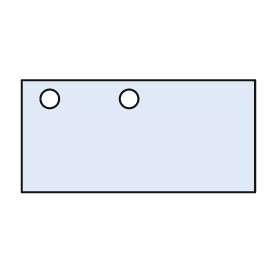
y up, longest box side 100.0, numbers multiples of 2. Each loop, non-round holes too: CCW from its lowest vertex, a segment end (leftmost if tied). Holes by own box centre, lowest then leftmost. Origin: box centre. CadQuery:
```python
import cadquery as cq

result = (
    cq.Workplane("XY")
    .moveTo(-50.0, -24.0)
    .lineTo(50.0, -24.0)
    .lineTo(50.0, 24.0)
    .lineTo(-50.0, 24.0)
    .close()
    .moveTo(-38.0, 16.0)
    .circle(4.0)
    .moveTo(-4.0, 16.0)
    .circle(4.0)
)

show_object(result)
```